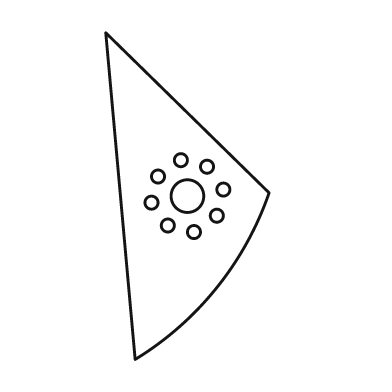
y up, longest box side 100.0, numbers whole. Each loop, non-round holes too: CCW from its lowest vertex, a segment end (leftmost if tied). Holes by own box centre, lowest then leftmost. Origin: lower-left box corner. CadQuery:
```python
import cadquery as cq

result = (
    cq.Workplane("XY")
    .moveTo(9.0, 0.0)
    .threePointArc((34.0, 22.0), (50.0, 51.0))
    .lineTo(0.0, 100.0)
    .close()
    .moveTo(27.0, 39.0)
    .circle(2.0)
    .moveTo(19.0, 41.0)
    .circle(2.0)
    .moveTo(34.0, 44.0)
    .circle(2.0)
    .moveTo(14.0, 48.0)
    .circle(2.0)
    .moveTo(25.0, 50.0)
    .circle(5.0)
    .moveTo(36.0, 52.0)
    .circle(2.0)
    .moveTo(16.0, 56.0)
    .circle(2.0)
    .moveTo(31.0, 59.0)
    .circle(2.0)
    .moveTo(23.0, 61.0)
    .circle(2.0)
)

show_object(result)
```